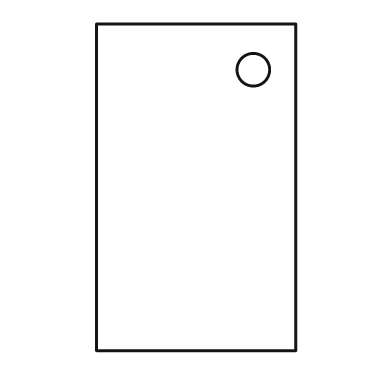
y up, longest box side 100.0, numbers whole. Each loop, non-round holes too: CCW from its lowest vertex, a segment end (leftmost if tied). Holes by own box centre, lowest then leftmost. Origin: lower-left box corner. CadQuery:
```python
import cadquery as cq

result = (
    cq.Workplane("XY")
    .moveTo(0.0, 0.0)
    .lineTo(61.0, 0.0)
    .lineTo(61.0, 100.0)
    .lineTo(0.0, 100.0)
    .close()
    .moveTo(48.0, 86.0)
    .circle(5.0)
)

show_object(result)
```